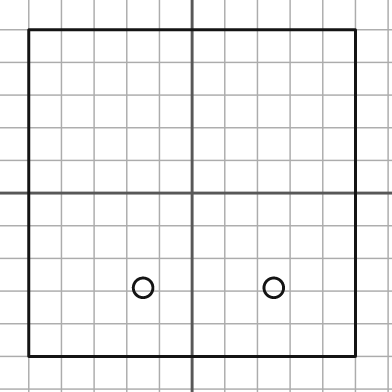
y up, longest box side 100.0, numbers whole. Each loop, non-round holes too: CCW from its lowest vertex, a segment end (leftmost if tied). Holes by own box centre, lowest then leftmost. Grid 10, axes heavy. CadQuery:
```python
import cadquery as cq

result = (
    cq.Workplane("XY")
    .moveTo(-50.0, -50.0)
    .lineTo(50.0, -50.0)
    .lineTo(50.0, 50.0)
    .lineTo(-50.0, 50.0)
    .close()
    .moveTo(-15.0, -29.0)
    .circle(3.0)
    .moveTo(25.0, -29.0)
    .circle(3.0)
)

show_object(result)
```